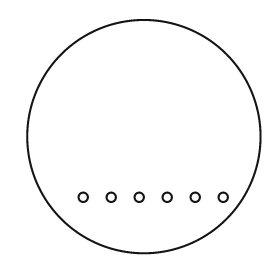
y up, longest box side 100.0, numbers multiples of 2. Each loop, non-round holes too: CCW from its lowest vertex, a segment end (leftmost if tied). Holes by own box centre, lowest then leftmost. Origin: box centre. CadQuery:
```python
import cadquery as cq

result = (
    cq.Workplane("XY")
    .moveTo(0.0, 0.0)
    .circle(50.0)
    .moveTo(-26.0, -26.0)
    .circle(2.0)
    .moveTo(-14.0, -26.0)
    .circle(2.0)
    .moveTo(-2.0, -26.0)
    .circle(2.0)
    .moveTo(10.0, -26.0)
    .circle(2.0)
    .moveTo(22.0, -26.0)
    .circle(2.0)
    .moveTo(34.0, -26.0)
    .circle(2.0)
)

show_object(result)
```